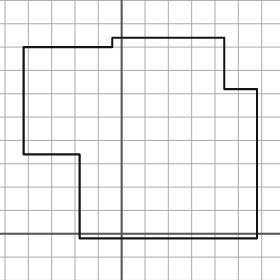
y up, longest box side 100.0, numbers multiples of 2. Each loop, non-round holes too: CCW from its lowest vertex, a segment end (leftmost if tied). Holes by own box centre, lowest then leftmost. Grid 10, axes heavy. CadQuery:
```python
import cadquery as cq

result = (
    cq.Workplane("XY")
    .moveTo(-18.0, -2.0)
    .lineTo(58.0, -2.0)
    .lineTo(58.0, 62.0)
    .lineTo(44.0, 62.0)
    .lineTo(44.0, 84.0)
    .lineTo(-4.0, 84.0)
    .lineTo(-4.0, 80.0)
    .lineTo(-42.0, 80.0)
    .lineTo(-42.0, 34.0)
    .lineTo(-18.0, 34.0)
    .close()
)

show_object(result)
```